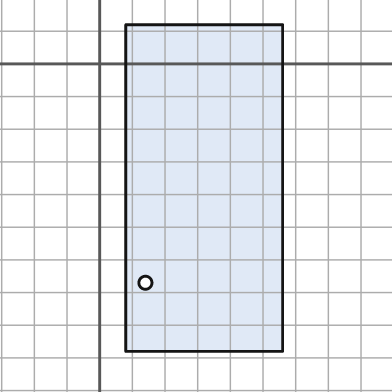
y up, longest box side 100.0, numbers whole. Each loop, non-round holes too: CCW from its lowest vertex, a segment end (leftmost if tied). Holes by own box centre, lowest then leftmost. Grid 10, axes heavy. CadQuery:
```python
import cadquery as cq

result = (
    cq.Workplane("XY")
    .moveTo(8.0, -88.0)
    .lineTo(56.0, -88.0)
    .lineTo(56.0, 12.0)
    .lineTo(8.0, 12.0)
    .close()
    .moveTo(14.0, -67.0)
    .circle(2.0)
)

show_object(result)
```